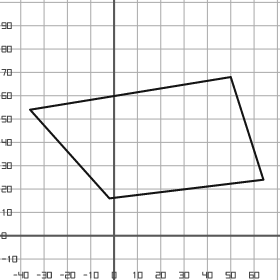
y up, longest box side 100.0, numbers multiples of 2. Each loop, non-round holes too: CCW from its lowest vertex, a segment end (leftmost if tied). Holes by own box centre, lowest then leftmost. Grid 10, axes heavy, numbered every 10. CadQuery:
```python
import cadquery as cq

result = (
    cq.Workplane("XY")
    .moveTo(-2.0, 16.0)
    .lineTo(64.0, 24.0)
    .lineTo(50.0, 68.0)
    .lineTo(-36.0, 54.0)
    .close()
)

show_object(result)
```